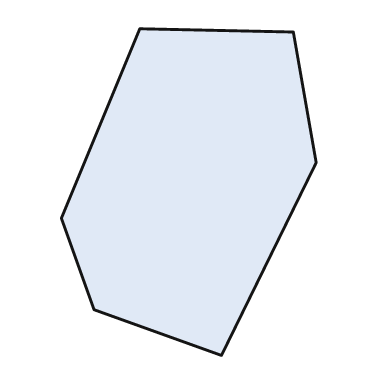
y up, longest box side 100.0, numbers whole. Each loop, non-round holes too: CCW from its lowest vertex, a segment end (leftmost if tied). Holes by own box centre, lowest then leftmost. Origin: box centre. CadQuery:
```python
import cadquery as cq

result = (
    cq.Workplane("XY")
    .moveTo(10.0, -50.0)
    .lineTo(39.0, 9.0)
    .lineTo(32.0, 49.0)
    .lineTo(-15.0, 50.0)
    .lineTo(-39.0, -8.0)
    .lineTo(-29.0, -36.0)
    .close()
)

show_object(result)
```